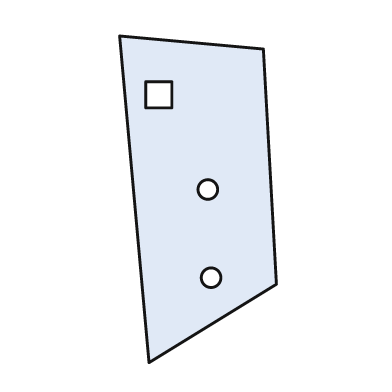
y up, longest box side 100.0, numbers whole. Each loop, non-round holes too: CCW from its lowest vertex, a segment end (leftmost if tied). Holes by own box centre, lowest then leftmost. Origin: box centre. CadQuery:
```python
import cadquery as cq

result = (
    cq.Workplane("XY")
    .moveTo(-15.0, -50.0)
    .lineTo(24.0, -26.0)
    .lineTo(20.0, 46.0)
    .lineTo(-24.0, 50.0)
    .close()
    .moveTo(4.0, -24.0)
    .circle(3.0)
    .moveTo(3.0, 3.0)
    .circle(3.0)
    .moveTo(-16.0, 28.0)
    .lineTo(-8.0, 28.0)
    .lineTo(-8.0, 36.0)
    .lineTo(-16.0, 36.0)
    .close()
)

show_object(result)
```